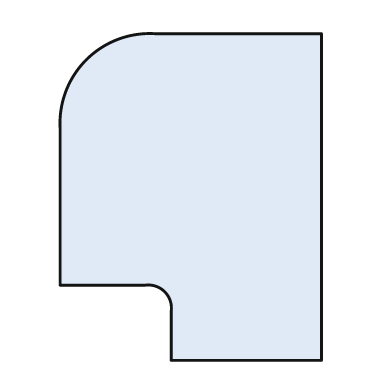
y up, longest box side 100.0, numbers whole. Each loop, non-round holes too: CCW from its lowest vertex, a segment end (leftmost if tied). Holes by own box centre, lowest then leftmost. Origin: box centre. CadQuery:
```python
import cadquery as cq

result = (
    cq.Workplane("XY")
    .moveTo(-6.0, -50.0)
    .lineTo(40.0, -50.0)
    .lineTo(40.0, 50.0)
    .lineTo(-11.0, 50.0)
    .threePointArc((-32.0, 42.0), (-40.0, 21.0))
    .lineTo(-40.0, -27.0)
    .lineTo(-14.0, -27.0)
    .threePointArc((-8.0, -29.0), (-6.0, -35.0))
    .close()
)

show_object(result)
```